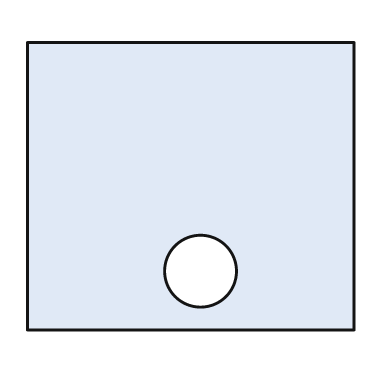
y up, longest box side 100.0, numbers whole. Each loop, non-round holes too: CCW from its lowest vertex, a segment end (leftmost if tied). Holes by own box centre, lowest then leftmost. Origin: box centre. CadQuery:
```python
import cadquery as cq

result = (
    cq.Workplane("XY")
    .moveTo(-50.0, -44.0)
    .lineTo(50.0, -44.0)
    .lineTo(50.0, 44.0)
    .lineTo(-50.0, 44.0)
    .close()
    .moveTo(3.0, -26.0)
    .circle(11.0)
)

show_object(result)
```